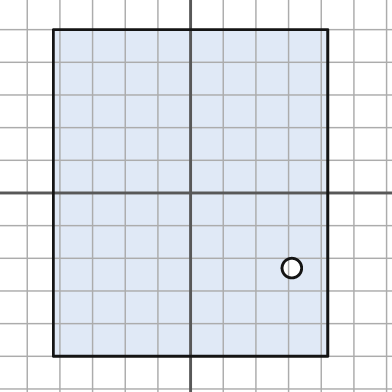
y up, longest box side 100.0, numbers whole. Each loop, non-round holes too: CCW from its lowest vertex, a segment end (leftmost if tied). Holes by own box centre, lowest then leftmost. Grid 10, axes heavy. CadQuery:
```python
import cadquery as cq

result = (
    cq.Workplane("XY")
    .moveTo(-42.0, -50.0)
    .lineTo(42.0, -50.0)
    .lineTo(42.0, 50.0)
    .lineTo(-42.0, 50.0)
    .close()
    .moveTo(31.0, -23.0)
    .circle(3.0)
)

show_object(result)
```